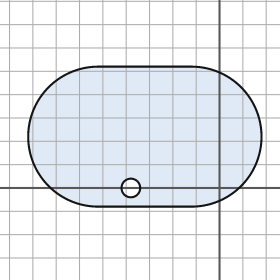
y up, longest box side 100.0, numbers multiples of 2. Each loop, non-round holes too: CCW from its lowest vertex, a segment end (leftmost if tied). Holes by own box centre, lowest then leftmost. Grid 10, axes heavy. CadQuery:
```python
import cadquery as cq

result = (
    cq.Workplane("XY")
    .moveTo(-52.0, -8.0)
    .lineTo(-12.0, -8.0)
    .threePointArc((18.0, 22.0), (-12.0, 52.0))
    .lineTo(-52.0, 52.0)
    .threePointArc((-82.0, 22.0), (-52.0, -8.0))
    .close()
    .moveTo(-38.0, 0.0)
    .circle(4.0)
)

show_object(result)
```